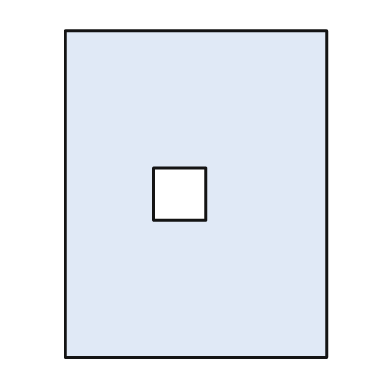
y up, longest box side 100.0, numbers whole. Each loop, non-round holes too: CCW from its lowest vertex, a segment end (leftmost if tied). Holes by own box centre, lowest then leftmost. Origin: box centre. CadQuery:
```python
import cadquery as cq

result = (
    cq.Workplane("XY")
    .moveTo(-40.0, -50.0)
    .lineTo(40.0, -50.0)
    .lineTo(40.0, 50.0)
    .lineTo(-40.0, 50.0)
    .close()
    .moveTo(-13.0, -8.0)
    .lineTo(3.0, -8.0)
    .lineTo(3.0, 8.0)
    .lineTo(-13.0, 8.0)
    .close()
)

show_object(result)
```